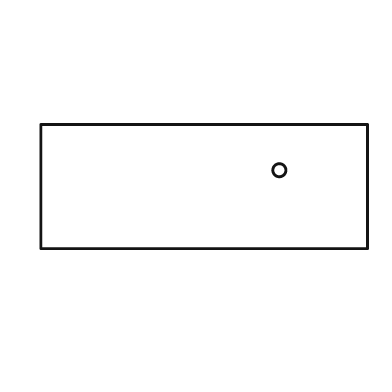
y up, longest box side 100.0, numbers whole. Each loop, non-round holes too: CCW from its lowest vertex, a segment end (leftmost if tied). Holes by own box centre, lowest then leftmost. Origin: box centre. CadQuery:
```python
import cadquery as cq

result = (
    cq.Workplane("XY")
    .moveTo(-50.0, -19.0)
    .lineTo(50.0, -19.0)
    .lineTo(50.0, 19.0)
    .lineTo(-50.0, 19.0)
    .close()
    .moveTo(23.0, 5.0)
    .circle(2.0)
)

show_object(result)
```